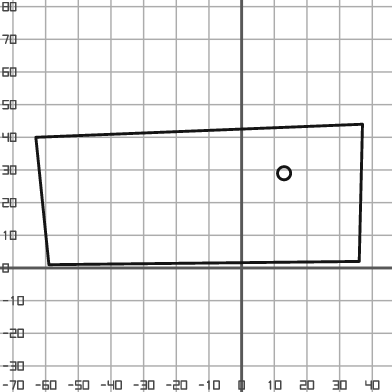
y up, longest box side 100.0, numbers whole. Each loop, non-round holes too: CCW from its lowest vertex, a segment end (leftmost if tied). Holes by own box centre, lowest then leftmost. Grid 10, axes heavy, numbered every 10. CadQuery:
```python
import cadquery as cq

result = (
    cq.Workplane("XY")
    .moveTo(-59.0, 1.0)
    .lineTo(36.0, 2.0)
    .lineTo(37.0, 44.0)
    .lineTo(-63.0, 40.0)
    .close()
    .moveTo(13.0, 29.0)
    .circle(2.0)
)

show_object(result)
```